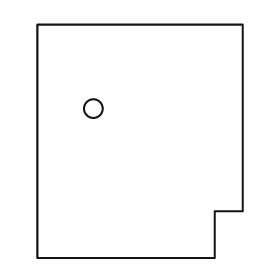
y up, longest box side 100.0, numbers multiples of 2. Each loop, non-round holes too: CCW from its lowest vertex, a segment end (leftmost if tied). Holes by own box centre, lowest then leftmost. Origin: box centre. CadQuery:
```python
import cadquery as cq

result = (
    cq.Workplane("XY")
    .moveTo(-44.0, -50.0)
    .lineTo(32.0, -50.0)
    .lineTo(32.0, -30.0)
    .lineTo(44.0, -30.0)
    .lineTo(44.0, 50.0)
    .lineTo(-44.0, 50.0)
    .close()
    .moveTo(-20.0, 14.0)
    .circle(4.0)
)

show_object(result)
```